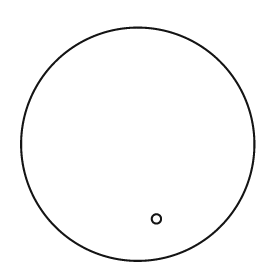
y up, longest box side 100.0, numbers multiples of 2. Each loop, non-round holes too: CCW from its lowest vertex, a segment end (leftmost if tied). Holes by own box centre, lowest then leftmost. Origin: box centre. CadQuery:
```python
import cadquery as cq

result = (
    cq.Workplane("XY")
    .moveTo(0.0, 0.0)
    .circle(50.0)
    .moveTo(8.0, -32.0)
    .circle(2.0)
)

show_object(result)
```